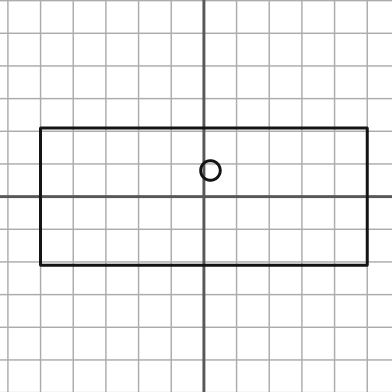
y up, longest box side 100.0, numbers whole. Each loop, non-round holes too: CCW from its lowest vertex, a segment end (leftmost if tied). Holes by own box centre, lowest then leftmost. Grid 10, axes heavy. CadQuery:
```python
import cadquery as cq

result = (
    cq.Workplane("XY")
    .moveTo(-50.0, -21.0)
    .lineTo(50.0, -21.0)
    .lineTo(50.0, 21.0)
    .lineTo(-50.0, 21.0)
    .close()
    .moveTo(2.0, 8.0)
    .circle(3.0)
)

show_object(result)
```